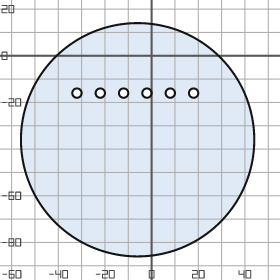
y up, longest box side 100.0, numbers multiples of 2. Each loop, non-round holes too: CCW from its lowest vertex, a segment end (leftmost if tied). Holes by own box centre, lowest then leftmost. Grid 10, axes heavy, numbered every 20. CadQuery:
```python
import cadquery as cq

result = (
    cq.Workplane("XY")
    .moveTo(-6.0, -36.0)
    .circle(50.0)
    .moveTo(-32.0, -16.0)
    .circle(2.0)
    .moveTo(-22.0, -16.0)
    .circle(2.0)
    .moveTo(-12.0, -16.0)
    .circle(2.0)
    .moveTo(-2.0, -16.0)
    .circle(2.0)
    .moveTo(8.0, -16.0)
    .circle(2.0)
    .moveTo(18.0, -16.0)
    .circle(2.0)
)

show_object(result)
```